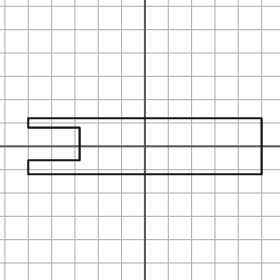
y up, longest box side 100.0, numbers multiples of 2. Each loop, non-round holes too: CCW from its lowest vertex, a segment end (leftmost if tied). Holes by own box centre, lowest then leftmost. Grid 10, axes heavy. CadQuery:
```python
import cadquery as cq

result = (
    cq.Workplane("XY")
    .moveTo(-50.0, -12.0)
    .lineTo(50.0, -12.0)
    .lineTo(50.0, 12.0)
    .lineTo(-50.0, 12.0)
    .lineTo(-50.0, 8.0)
    .lineTo(-28.0, 8.0)
    .lineTo(-28.0, -6.0)
    .lineTo(-50.0, -6.0)
    .close()
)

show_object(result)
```